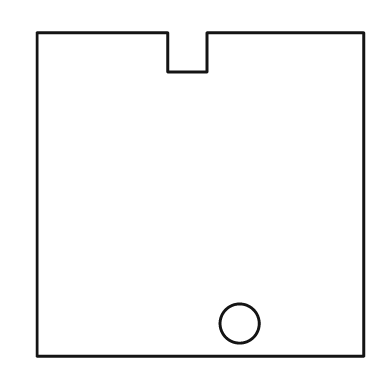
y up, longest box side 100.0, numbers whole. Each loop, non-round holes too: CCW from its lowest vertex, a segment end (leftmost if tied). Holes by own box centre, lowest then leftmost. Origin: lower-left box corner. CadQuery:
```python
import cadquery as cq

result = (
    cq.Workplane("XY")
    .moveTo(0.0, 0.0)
    .lineTo(100.0, 0.0)
    .lineTo(100.0, 99.0)
    .lineTo(52.0, 99.0)
    .lineTo(52.0, 87.0)
    .lineTo(40.0, 87.0)
    .lineTo(40.0, 99.0)
    .lineTo(0.0, 99.0)
    .close()
    .moveTo(62.0, 10.0)
    .circle(6.0)
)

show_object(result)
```